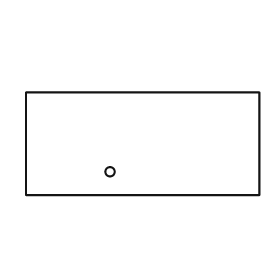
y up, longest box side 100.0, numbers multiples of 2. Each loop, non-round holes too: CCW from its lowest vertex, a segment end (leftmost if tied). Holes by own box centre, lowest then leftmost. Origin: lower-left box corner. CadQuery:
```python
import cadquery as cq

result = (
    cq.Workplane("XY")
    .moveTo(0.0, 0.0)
    .lineTo(100.0, 0.0)
    .lineTo(100.0, 44.0)
    .lineTo(0.0, 44.0)
    .close()
    .moveTo(36.0, 10.0)
    .circle(2.0)
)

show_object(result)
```